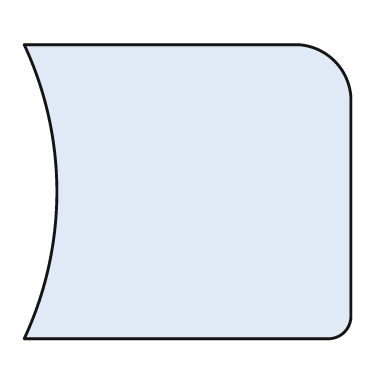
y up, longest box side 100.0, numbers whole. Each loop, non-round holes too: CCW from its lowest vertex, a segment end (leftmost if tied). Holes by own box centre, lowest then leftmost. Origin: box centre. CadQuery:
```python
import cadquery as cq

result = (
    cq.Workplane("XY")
    .moveTo(-50.0, -45.0)
    .lineTo(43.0, -45.0)
    .threePointArc((48.0, -43.0), (50.0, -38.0))
    .lineTo(50.0, 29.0)
    .threePointArc((45.0, 40.0), (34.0, 45.0))
    .lineTo(-50.0, 45.0)
    .threePointArc((-40.0, 0.0), (-50.0, -45.0))
    .close()
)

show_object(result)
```